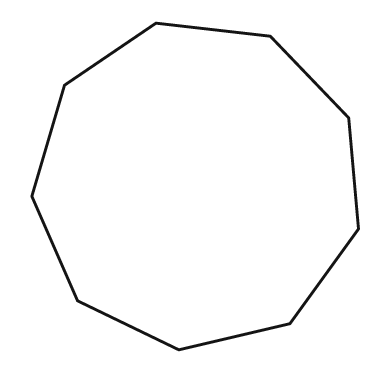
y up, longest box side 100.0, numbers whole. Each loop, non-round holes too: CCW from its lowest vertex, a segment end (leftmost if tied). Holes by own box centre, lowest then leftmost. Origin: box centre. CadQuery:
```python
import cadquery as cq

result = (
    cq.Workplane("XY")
    .moveTo(-5.0, -50.0)
    .lineTo(29.0, -42.0)
    .lineTo(50.0, -13.0)
    .lineTo(47.0, 21.0)
    .lineTo(23.0, 46.0)
    .lineTo(-12.0, 50.0)
    .lineTo(-40.0, 31.0)
    .lineTo(-50.0, -3.0)
    .lineTo(-36.0, -35.0)
    .close()
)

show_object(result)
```